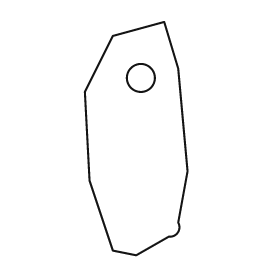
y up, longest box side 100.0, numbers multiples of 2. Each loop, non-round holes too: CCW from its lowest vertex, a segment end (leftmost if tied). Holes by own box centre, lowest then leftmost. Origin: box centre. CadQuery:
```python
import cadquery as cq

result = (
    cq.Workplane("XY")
    .moveTo(0.0, -50.0)
    .lineTo(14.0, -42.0)
    .threePointArc((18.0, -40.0), (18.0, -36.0))
    .lineTo(22.0, -14.0)
    .lineTo(18.0, 30.0)
    .lineTo(12.0, 50.0)
    .lineTo(-10.0, 44.0)
    .lineTo(-22.0, 20.0)
    .lineTo(-20.0, -18.0)
    .lineTo(-10.0, -48.0)
    .close()
    .moveTo(2.0, 26.0)
    .circle(6.0)
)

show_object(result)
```